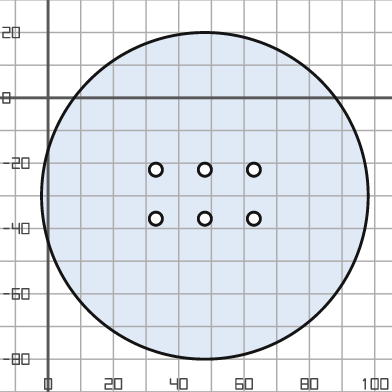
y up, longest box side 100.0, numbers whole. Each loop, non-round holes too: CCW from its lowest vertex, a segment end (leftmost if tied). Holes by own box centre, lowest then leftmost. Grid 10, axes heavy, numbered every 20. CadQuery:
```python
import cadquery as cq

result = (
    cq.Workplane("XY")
    .moveTo(48.0, -30.0)
    .circle(50.0)
    .moveTo(33.0, -37.0)
    .circle(2.0)
    .moveTo(48.0, -37.0)
    .circle(2.0)
    .moveTo(63.0, -37.0)
    .circle(2.0)
    .moveTo(33.0, -22.0)
    .circle(2.0)
    .moveTo(48.0, -22.0)
    .circle(2.0)
    .moveTo(63.0, -22.0)
    .circle(2.0)
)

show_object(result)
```